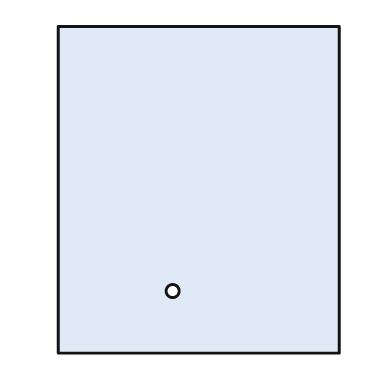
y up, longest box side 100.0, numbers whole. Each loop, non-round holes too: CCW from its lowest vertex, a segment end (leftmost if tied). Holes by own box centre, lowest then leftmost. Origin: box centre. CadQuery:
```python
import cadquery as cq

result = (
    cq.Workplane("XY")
    .moveTo(-43.0, -50.0)
    .lineTo(43.0, -50.0)
    .lineTo(43.0, 50.0)
    .lineTo(-43.0, 50.0)
    .close()
    .moveTo(-8.0, -31.0)
    .circle(2.0)
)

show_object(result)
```